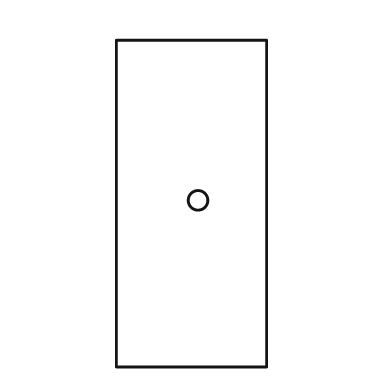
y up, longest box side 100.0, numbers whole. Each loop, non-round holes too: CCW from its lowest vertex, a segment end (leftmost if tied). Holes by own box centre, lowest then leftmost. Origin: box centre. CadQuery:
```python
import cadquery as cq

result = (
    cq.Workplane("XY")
    .moveTo(-23.0, -50.0)
    .lineTo(23.0, -50.0)
    .lineTo(23.0, 50.0)
    .lineTo(-23.0, 50.0)
    .close()
    .moveTo(2.0, 1.0)
    .circle(3.0)
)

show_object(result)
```